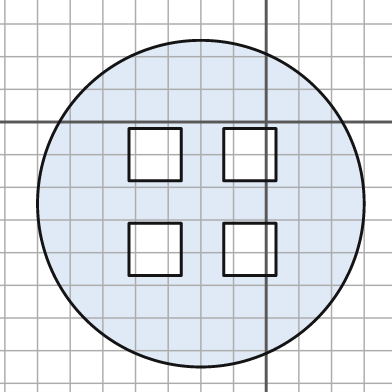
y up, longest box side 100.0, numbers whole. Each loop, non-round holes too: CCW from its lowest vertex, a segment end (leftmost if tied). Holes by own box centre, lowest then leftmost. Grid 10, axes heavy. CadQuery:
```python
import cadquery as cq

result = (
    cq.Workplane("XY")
    .moveTo(-20.0, -25.0)
    .circle(50.0)
    .moveTo(-42.0, -47.0)
    .lineTo(-26.0, -47.0)
    .lineTo(-26.0, -31.0)
    .lineTo(-42.0, -31.0)
    .close()
    .moveTo(-13.0, -47.0)
    .lineTo(3.0, -47.0)
    .lineTo(3.0, -31.0)
    .lineTo(-13.0, -31.0)
    .close()
    .moveTo(-42.0, -18.0)
    .lineTo(-26.0, -18.0)
    .lineTo(-26.0, -2.0)
    .lineTo(-42.0, -2.0)
    .close()
    .moveTo(-13.0, -18.0)
    .lineTo(3.0, -18.0)
    .lineTo(3.0, -2.0)
    .lineTo(-13.0, -2.0)
    .close()
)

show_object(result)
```